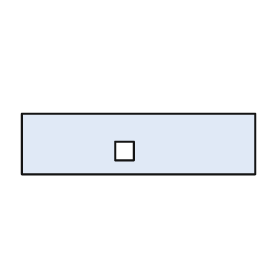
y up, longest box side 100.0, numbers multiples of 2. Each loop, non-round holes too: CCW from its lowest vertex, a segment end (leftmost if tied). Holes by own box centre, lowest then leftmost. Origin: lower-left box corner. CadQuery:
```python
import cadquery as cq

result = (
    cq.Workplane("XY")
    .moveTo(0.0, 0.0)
    .lineTo(100.0, 0.0)
    .lineTo(100.0, 26.0)
    .lineTo(0.0, 26.0)
    .close()
    .moveTo(40.0, 6.0)
    .lineTo(48.0, 6.0)
    .lineTo(48.0, 14.0)
    .lineTo(40.0, 14.0)
    .close()
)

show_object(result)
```